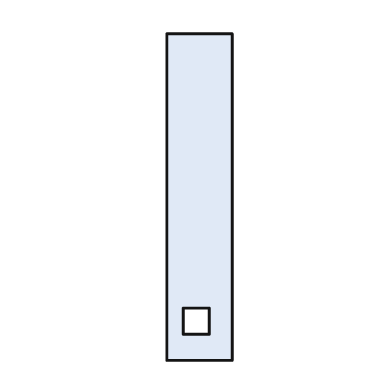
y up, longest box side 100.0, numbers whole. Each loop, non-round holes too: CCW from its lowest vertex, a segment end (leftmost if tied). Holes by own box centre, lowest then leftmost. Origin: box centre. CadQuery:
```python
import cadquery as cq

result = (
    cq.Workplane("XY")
    .moveTo(-10.0, -50.0)
    .lineTo(10.0, -50.0)
    .lineTo(10.0, 50.0)
    .lineTo(-10.0, 50.0)
    .close()
    .moveTo(-5.0, -42.0)
    .lineTo(3.0, -42.0)
    .lineTo(3.0, -34.0)
    .lineTo(-5.0, -34.0)
    .close()
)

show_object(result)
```